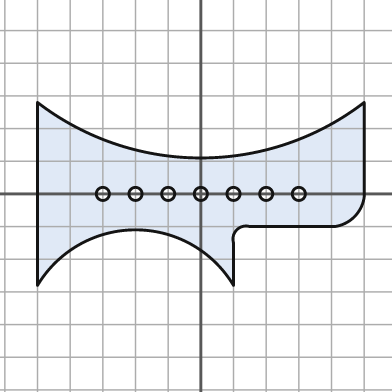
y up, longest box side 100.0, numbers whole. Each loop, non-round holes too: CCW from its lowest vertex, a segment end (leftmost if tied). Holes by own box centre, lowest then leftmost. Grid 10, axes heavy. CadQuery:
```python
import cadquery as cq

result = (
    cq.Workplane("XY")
    .moveTo(-50.0, -28.0)
    .threePointArc((-20.0, -11.0), (10.0, -28.0))
    .lineTo(10.0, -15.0)
    .threePointArc((11.0, -11.0), (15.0, -10.0))
    .lineTo(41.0, -10.0)
    .threePointArc((47.0, -7.0), (50.0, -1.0))
    .lineTo(50.0, 28.0)
    .threePointArc((0.0, 11.0), (-50.0, 28.0))
    .close()
    .moveTo(-30.0, 0.0)
    .circle(2.0)
    .moveTo(-20.0, 0.0)
    .circle(2.0)
    .moveTo(-10.0, 0.0)
    .circle(2.0)
    .moveTo(0.0, 0.0)
    .circle(2.0)
    .moveTo(10.0, 0.0)
    .circle(2.0)
    .moveTo(20.0, 0.0)
    .circle(2.0)
    .moveTo(30.0, 0.0)
    .circle(2.0)
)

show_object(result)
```